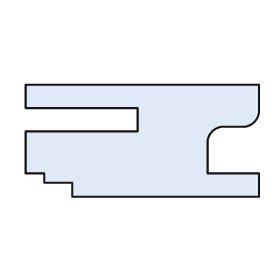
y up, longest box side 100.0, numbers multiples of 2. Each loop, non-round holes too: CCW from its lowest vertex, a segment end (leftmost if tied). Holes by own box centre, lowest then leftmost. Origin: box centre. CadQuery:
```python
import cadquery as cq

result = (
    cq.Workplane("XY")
    .moveTo(-30.0, -24.0)
    .lineTo(50.0, -24.0)
    .lineTo(50.0, -14.0)
    .lineTo(28.0, -14.0)
    .lineTo(28.0, 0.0)
    .threePointArc((30.0, 4.0), (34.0, 6.0))
    .lineTo(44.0, 6.0)
    .threePointArc((48.0, 8.0), (50.0, 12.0))
    .lineTo(50.0, 24.0)
    .lineTo(-50.0, 24.0)
    .lineTo(-50.0, 14.0)
    .lineTo(-2.0, 14.0)
    .lineTo(-2.0, 4.0)
    .lineTo(-50.0, 4.0)
    .lineTo(-50.0, -14.0)
    .lineTo(-42.0, -14.0)
    .lineTo(-42.0, -18.0)
    .lineTo(-30.0, -18.0)
    .close()
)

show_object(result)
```